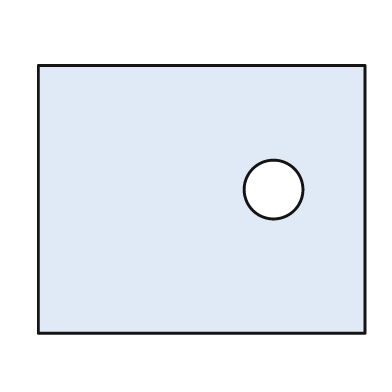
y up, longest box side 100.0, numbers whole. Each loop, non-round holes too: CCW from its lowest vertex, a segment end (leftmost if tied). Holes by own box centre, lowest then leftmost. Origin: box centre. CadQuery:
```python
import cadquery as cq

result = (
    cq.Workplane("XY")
    .moveTo(-50.0, -41.0)
    .lineTo(50.0, -41.0)
    .lineTo(50.0, 41.0)
    .lineTo(-50.0, 41.0)
    .close()
    .moveTo(22.0, 3.0)
    .circle(9.0)
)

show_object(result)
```